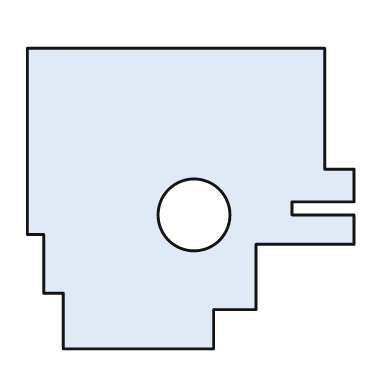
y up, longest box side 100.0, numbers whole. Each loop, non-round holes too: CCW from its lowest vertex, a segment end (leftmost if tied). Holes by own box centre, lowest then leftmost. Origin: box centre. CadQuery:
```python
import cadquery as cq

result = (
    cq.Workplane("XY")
    .moveTo(-39.0, -46.0)
    .lineTo(7.0, -46.0)
    .lineTo(7.0, -34.0)
    .lineTo(20.0, -34.0)
    .lineTo(20.0, -14.0)
    .lineTo(50.0, -14.0)
    .lineTo(50.0, -5.0)
    .lineTo(31.0, -5.0)
    .lineTo(31.0, -1.0)
    .lineTo(50.0, -1.0)
    .lineTo(50.0, 9.0)
    .lineTo(41.0, 9.0)
    .lineTo(41.0, 46.0)
    .lineTo(-50.0, 46.0)
    .lineTo(-50.0, -11.0)
    .lineTo(-45.0, -11.0)
    .lineTo(-45.0, -29.0)
    .lineTo(-39.0, -29.0)
    .close()
    .moveTo(1.0, -5.0)
    .circle(11.0)
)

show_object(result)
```